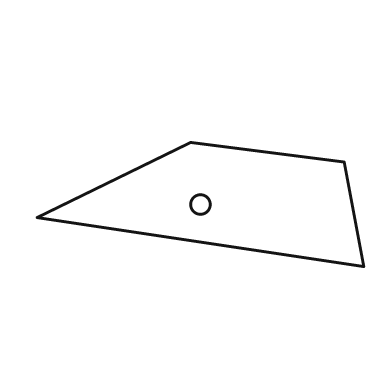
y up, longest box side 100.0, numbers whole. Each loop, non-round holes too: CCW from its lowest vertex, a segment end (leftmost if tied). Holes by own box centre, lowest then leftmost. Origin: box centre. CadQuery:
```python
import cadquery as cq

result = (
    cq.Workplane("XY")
    .moveTo(50.0, -19.0)
    .lineTo(44.0, 13.0)
    .lineTo(-3.0, 19.0)
    .lineTo(-50.0, -4.0)
    .close()
    .moveTo(0.0, 0.0)
    .circle(3.0)
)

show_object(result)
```